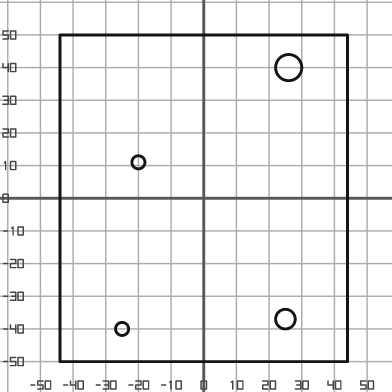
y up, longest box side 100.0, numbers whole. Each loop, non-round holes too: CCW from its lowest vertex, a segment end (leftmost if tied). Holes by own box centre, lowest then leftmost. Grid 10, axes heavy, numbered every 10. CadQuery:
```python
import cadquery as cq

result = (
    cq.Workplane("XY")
    .moveTo(-44.0, -50.0)
    .lineTo(44.0, -50.0)
    .lineTo(44.0, 50.0)
    .lineTo(-44.0, 50.0)
    .close()
    .moveTo(-25.0, -40.0)
    .circle(2.0)
    .moveTo(25.0, -37.0)
    .circle(3.0)
    .moveTo(-20.0, 11.0)
    .circle(2.0)
    .moveTo(26.0, 40.0)
    .circle(4.0)
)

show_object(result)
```